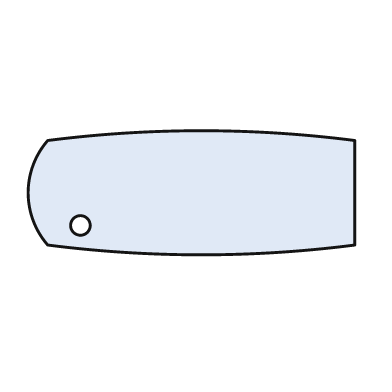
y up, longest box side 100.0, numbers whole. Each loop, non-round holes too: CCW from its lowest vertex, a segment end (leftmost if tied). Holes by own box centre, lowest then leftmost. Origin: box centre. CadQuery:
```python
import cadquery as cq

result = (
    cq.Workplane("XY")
    .moveTo(-44.0, -16.0)
    .threePointArc((3.0, -19.0), (50.0, -16.0))
    .lineTo(50.0, 16.0)
    .threePointArc((3.0, 19.0), (-44.0, 16.0))
    .threePointArc((-50.0, 0.0), (-44.0, -16.0))
    .close()
    .moveTo(-34.0, -10.0)
    .circle(3.0)
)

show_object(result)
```